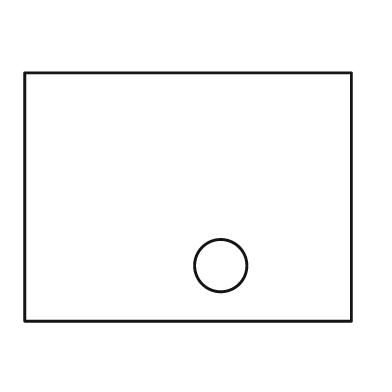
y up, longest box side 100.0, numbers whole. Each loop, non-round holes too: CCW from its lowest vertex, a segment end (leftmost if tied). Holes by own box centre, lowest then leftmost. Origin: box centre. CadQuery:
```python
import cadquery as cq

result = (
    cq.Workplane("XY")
    .moveTo(-50.0, -38.0)
    .lineTo(50.0, -38.0)
    .lineTo(50.0, 38.0)
    .lineTo(-50.0, 38.0)
    .close()
    .moveTo(10.0, -21.0)
    .circle(8.0)
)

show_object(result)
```